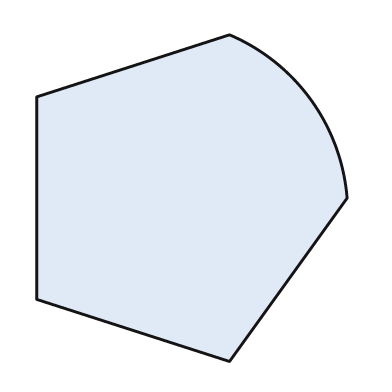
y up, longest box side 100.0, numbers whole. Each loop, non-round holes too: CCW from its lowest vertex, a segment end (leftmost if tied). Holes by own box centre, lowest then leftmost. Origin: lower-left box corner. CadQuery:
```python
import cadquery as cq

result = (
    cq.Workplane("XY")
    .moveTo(59.0, 0.0)
    .lineTo(95.0, 50.0)
    .threePointArc((84.0, 80.0), (59.0, 100.0))
    .lineTo(0.0, 81.0)
    .lineTo(0.0, 19.0)
    .close()
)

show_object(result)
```